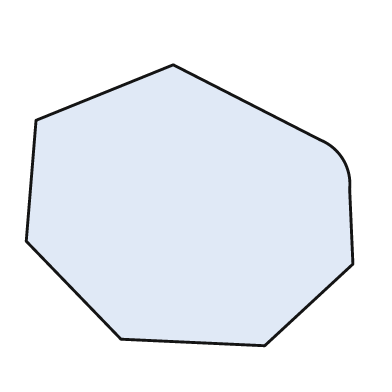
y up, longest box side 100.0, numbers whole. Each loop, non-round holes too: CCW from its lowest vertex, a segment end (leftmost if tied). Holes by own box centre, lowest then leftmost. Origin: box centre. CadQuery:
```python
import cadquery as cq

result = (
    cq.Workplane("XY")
    .moveTo(23.0, -43.0)
    .lineTo(50.0, -18.0)
    .lineTo(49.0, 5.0)
    .threePointArc((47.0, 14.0), (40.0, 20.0))
    .lineTo(-5.0, 43.0)
    .lineTo(-47.0, 26.0)
    .lineTo(-50.0, -11.0)
    .lineTo(-21.0, -41.0)
    .close()
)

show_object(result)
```